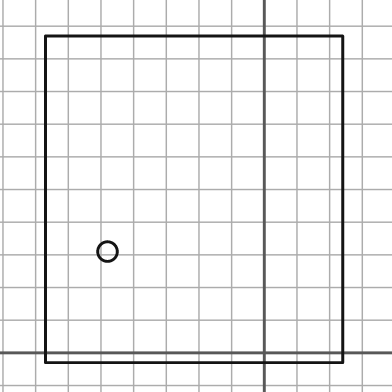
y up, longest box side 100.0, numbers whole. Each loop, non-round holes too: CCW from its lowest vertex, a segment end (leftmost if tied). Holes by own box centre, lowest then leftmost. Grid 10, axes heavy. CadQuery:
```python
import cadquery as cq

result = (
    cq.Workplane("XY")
    .moveTo(-67.0, -3.0)
    .lineTo(24.0, -3.0)
    .lineTo(24.0, 97.0)
    .lineTo(-67.0, 97.0)
    .close()
    .moveTo(-48.0, 31.0)
    .circle(3.0)
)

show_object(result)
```